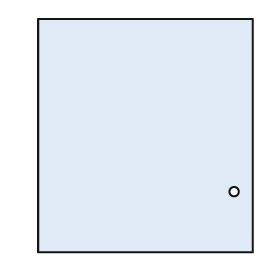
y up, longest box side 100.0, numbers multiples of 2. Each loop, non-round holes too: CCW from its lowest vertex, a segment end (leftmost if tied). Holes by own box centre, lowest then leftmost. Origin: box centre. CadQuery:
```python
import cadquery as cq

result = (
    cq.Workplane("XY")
    .moveTo(-46.0, -50.0)
    .lineTo(46.0, -50.0)
    .lineTo(46.0, 50.0)
    .lineTo(-46.0, 50.0)
    .close()
    .moveTo(38.0, -24.0)
    .circle(2.0)
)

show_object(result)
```